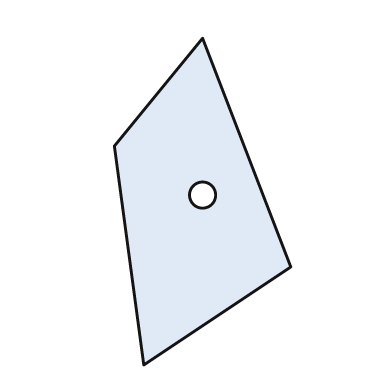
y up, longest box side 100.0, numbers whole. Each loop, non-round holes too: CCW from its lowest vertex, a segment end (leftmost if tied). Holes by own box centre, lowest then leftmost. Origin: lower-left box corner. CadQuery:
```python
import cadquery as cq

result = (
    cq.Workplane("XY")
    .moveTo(9.0, 0.0)
    .lineTo(54.0, 30.0)
    .lineTo(27.0, 100.0)
    .lineTo(0.0, 67.0)
    .close()
    .moveTo(27.0, 52.0)
    .circle(4.0)
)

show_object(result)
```